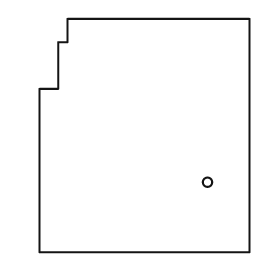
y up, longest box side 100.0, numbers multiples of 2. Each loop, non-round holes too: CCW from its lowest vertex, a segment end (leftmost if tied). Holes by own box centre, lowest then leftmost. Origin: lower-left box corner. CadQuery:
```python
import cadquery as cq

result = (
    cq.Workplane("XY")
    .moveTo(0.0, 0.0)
    .lineTo(90.0, 0.0)
    .lineTo(90.0, 100.0)
    .lineTo(12.0, 100.0)
    .lineTo(12.0, 90.0)
    .lineTo(8.0, 90.0)
    .lineTo(8.0, 70.0)
    .lineTo(0.0, 70.0)
    .close()
    .moveTo(72.0, 30.0)
    .circle(2.0)
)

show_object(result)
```